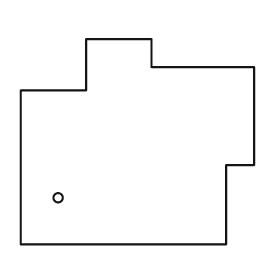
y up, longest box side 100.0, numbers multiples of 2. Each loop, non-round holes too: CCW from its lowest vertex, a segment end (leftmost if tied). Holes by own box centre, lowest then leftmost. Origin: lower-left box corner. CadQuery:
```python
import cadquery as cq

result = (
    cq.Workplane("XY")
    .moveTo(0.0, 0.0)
    .lineTo(88.0, 0.0)
    .lineTo(88.0, 34.0)
    .lineTo(100.0, 34.0)
    .lineTo(100.0, 76.0)
    .lineTo(56.0, 76.0)
    .lineTo(56.0, 88.0)
    .lineTo(28.0, 88.0)
    .lineTo(28.0, 66.0)
    .lineTo(0.0, 66.0)
    .close()
    .moveTo(16.0, 20.0)
    .circle(2.0)
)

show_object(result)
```